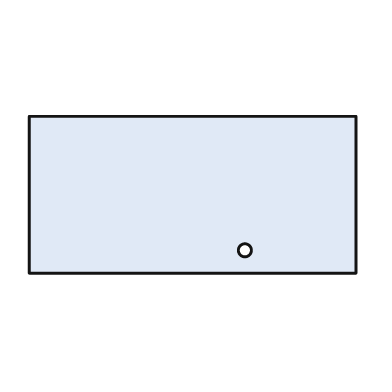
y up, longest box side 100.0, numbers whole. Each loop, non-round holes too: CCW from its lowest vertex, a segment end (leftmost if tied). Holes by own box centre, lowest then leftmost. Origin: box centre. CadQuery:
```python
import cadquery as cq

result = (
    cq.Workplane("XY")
    .moveTo(-50.0, -24.0)
    .lineTo(50.0, -24.0)
    .lineTo(50.0, 24.0)
    .lineTo(-50.0, 24.0)
    .close()
    .moveTo(16.0, -17.0)
    .circle(2.0)
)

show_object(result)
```